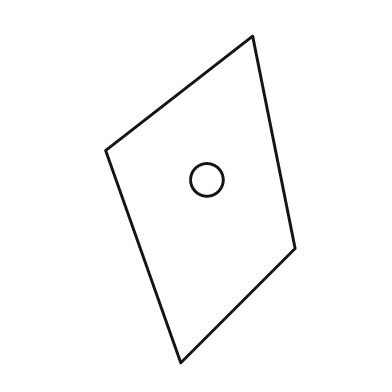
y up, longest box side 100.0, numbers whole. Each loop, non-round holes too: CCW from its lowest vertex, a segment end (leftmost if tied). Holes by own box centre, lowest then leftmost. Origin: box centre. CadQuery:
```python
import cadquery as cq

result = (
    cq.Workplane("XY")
    .moveTo(-6.0, -50.0)
    .lineTo(29.0, -15.0)
    .lineTo(16.0, 50.0)
    .lineTo(-29.0, 15.0)
    .close()
    .moveTo(2.0, 6.0)
    .circle(5.0)
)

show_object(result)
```